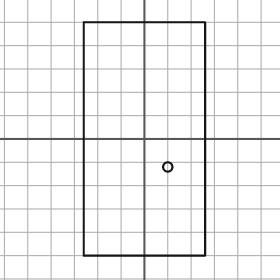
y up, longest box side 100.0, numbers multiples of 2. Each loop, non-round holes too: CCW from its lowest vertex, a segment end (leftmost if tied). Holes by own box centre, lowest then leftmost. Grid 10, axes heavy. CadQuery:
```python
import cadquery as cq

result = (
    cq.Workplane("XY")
    .moveTo(-26.0, -50.0)
    .lineTo(26.0, -50.0)
    .lineTo(26.0, 50.0)
    .lineTo(-26.0, 50.0)
    .close()
    .moveTo(10.0, -12.0)
    .circle(2.0)
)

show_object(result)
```